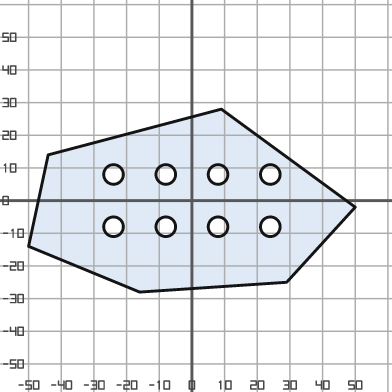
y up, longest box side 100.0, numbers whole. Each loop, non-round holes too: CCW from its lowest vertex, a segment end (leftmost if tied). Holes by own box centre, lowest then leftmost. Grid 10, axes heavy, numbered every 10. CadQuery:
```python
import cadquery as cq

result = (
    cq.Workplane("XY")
    .moveTo(-16.0, -28.0)
    .lineTo(29.0, -25.0)
    .lineTo(50.0, -2.0)
    .lineTo(9.0, 28.0)
    .lineTo(-44.0, 14.0)
    .lineTo(-50.0, -14.0)
    .close()
    .moveTo(-24.0, -8.0)
    .circle(3.0)
    .moveTo(-8.0, -8.0)
    .circle(3.0)
    .moveTo(8.0, -8.0)
    .circle(3.0)
    .moveTo(24.0, -8.0)
    .circle(3.0)
    .moveTo(-24.0, 8.0)
    .circle(3.0)
    .moveTo(-8.0, 8.0)
    .circle(3.0)
    .moveTo(8.0, 8.0)
    .circle(3.0)
    .moveTo(24.0, 8.0)
    .circle(3.0)
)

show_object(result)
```